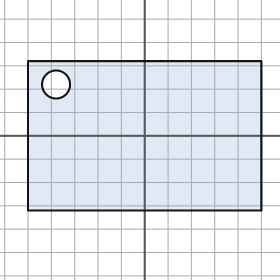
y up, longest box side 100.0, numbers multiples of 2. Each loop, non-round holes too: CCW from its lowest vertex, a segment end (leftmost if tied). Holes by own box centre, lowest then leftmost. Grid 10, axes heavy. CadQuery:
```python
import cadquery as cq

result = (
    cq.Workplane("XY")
    .moveTo(-50.0, -32.0)
    .lineTo(50.0, -32.0)
    .lineTo(50.0, 32.0)
    .lineTo(-50.0, 32.0)
    .close()
    .moveTo(-38.0, 22.0)
    .circle(6.0)
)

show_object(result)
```